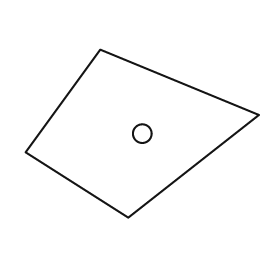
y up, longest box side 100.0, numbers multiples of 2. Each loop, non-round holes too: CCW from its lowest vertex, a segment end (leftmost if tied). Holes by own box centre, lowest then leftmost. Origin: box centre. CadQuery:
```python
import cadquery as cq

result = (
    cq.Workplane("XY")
    .moveTo(-6.0, -36.0)
    .lineTo(50.0, 8.0)
    .lineTo(-18.0, 36.0)
    .lineTo(-50.0, -8.0)
    .close()
    .moveTo(0.0, 0.0)
    .circle(4.0)
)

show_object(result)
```